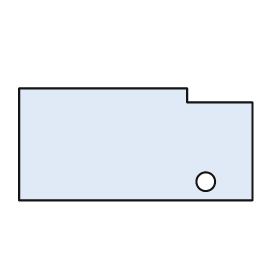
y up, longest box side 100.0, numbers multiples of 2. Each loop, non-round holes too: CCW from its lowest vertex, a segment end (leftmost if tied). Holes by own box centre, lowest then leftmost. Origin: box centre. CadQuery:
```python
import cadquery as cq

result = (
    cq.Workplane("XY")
    .moveTo(-50.0, -24.0)
    .lineTo(50.0, -24.0)
    .lineTo(50.0, 18.0)
    .lineTo(22.0, 18.0)
    .lineTo(22.0, 24.0)
    .lineTo(-50.0, 24.0)
    .close()
    .moveTo(30.0, -16.0)
    .circle(4.0)
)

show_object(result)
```